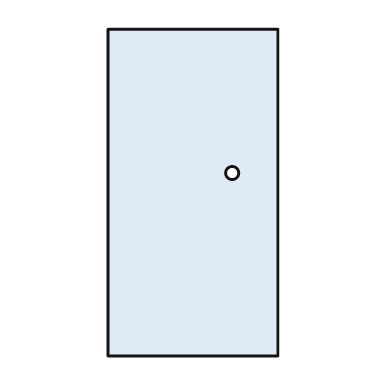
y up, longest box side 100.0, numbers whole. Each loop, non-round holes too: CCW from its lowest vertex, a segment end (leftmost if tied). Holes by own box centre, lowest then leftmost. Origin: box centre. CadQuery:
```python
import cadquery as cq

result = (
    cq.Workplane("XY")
    .moveTo(-26.0, -50.0)
    .lineTo(26.0, -50.0)
    .lineTo(26.0, 50.0)
    .lineTo(-26.0, 50.0)
    .close()
    .moveTo(12.0, 6.0)
    .circle(2.0)
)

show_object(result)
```